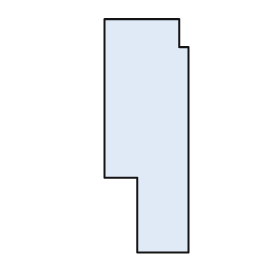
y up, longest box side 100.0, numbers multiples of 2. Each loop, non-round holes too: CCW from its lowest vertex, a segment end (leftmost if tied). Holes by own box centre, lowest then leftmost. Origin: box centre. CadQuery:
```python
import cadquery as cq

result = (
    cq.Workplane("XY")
    .moveTo(-4.0, -50.0)
    .lineTo(18.0, -50.0)
    .lineTo(18.0, 38.0)
    .lineTo(14.0, 38.0)
    .lineTo(14.0, 50.0)
    .lineTo(-18.0, 50.0)
    .lineTo(-18.0, -18.0)
    .lineTo(-4.0, -18.0)
    .close()
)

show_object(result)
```